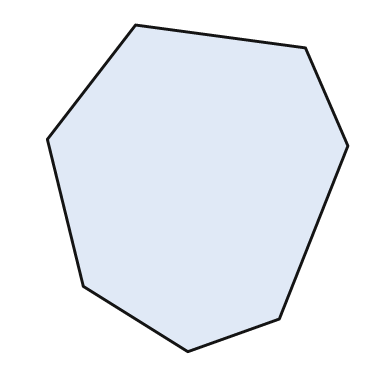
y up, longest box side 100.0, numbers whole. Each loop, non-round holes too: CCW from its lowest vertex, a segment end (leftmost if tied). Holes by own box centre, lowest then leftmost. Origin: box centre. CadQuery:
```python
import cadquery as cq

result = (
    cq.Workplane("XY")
    .moveTo(-3.0, -50.0)
    .lineTo(25.0, -40.0)
    .lineTo(46.0, 13.0)
    .lineTo(33.0, 43.0)
    .lineTo(-19.0, 50.0)
    .lineTo(-46.0, 15.0)
    .lineTo(-35.0, -30.0)
    .close()
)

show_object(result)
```